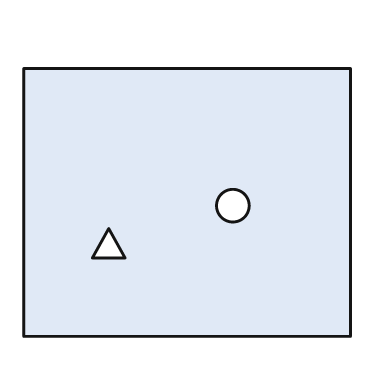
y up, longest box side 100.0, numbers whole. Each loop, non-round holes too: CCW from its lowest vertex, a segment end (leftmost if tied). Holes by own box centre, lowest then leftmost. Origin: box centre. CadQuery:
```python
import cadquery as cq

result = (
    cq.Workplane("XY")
    .moveTo(-50.0, -41.0)
    .lineTo(50.0, -41.0)
    .lineTo(50.0, 41.0)
    .lineTo(-50.0, 41.0)
    .close()
    .moveTo(-29.0, -17.0)
    .lineTo(-19.0, -17.0)
    .lineTo(-24.0, -8.0)
    .close()
    .moveTo(14.0, -1.0)
    .circle(5.0)
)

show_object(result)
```